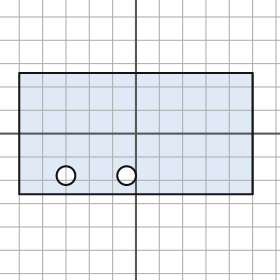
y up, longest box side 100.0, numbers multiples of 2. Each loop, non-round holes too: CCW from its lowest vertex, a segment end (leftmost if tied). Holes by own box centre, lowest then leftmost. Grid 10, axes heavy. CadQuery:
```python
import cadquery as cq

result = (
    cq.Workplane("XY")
    .moveTo(-50.0, -26.0)
    .lineTo(50.0, -26.0)
    .lineTo(50.0, 26.0)
    .lineTo(-50.0, 26.0)
    .close()
    .moveTo(-30.0, -18.0)
    .circle(4.0)
    .moveTo(-4.0, -18.0)
    .circle(4.0)
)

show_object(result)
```